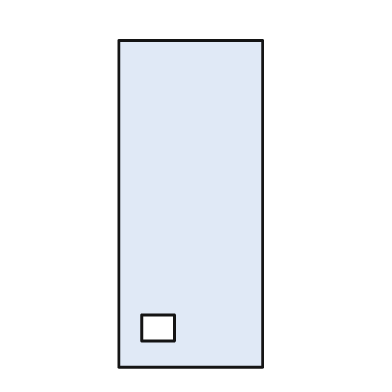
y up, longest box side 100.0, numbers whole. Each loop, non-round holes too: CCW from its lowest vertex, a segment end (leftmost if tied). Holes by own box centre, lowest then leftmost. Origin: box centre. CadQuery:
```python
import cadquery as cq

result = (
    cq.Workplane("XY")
    .moveTo(-22.0, -50.0)
    .lineTo(22.0, -50.0)
    .lineTo(22.0, 50.0)
    .lineTo(-22.0, 50.0)
    .close()
    .moveTo(-15.0, -42.0)
    .lineTo(-5.0, -42.0)
    .lineTo(-5.0, -34.0)
    .lineTo(-15.0, -34.0)
    .close()
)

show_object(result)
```